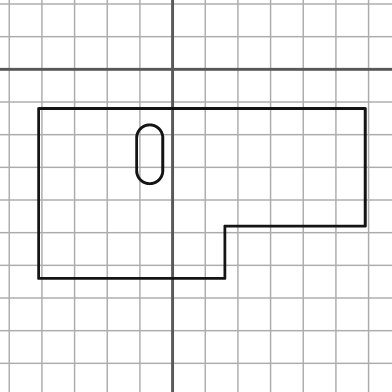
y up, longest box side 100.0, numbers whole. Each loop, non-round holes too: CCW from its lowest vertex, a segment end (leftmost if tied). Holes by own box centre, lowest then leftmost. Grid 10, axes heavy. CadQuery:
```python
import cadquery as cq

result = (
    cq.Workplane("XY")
    .moveTo(-41.0, -64.0)
    .lineTo(16.0, -64.0)
    .lineTo(16.0, -48.0)
    .lineTo(59.0, -48.0)
    .lineTo(59.0, -12.0)
    .lineTo(-41.0, -12.0)
    .close()
    .moveTo(-11.0, -31.0)
    .threePointArc((-7.0, -35.0), (-3.0, -31.0))
    .lineTo(-3.0, -21.0)
    .threePointArc((-7.0, -17.0), (-11.0, -21.0))
    .close()
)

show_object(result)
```